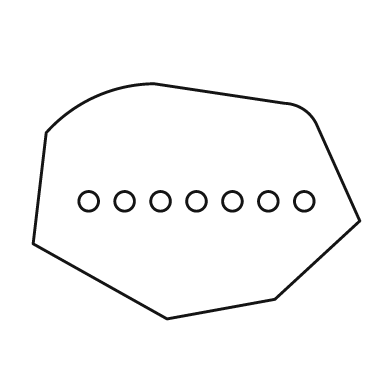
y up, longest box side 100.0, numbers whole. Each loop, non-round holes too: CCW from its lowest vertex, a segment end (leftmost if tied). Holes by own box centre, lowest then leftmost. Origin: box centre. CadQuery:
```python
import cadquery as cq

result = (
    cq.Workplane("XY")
    .moveTo(-9.0, -36.0)
    .lineTo(24.0, -30.0)
    .lineTo(50.0, -6.0)
    .lineTo(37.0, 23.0)
    .threePointArc((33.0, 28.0), (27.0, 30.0))
    .lineTo(-13.0, 36.0)
    .threePointArc((-31.0, 32.0), (-46.0, 21.0))
    .lineTo(-50.0, -13.0)
    .close()
    .moveTo(-33.0, 0.0)
    .circle(3.0)
    .moveTo(-22.0, 0.0)
    .circle(3.0)
    .moveTo(-11.0, 0.0)
    .circle(3.0)
    .moveTo(0.0, 0.0)
    .circle(3.0)
    .moveTo(11.0, 0.0)
    .circle(3.0)
    .moveTo(22.0, 0.0)
    .circle(3.0)
    .moveTo(33.0, 0.0)
    .circle(3.0)
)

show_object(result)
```